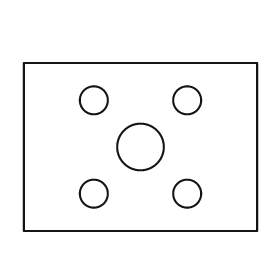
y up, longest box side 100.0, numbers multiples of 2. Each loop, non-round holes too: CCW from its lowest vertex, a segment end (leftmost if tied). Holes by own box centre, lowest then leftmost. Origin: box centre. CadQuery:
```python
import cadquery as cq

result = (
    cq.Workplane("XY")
    .moveTo(-50.0, -36.0)
    .lineTo(50.0, -36.0)
    .lineTo(50.0, 36.0)
    .lineTo(-50.0, 36.0)
    .close()
    .moveTo(-20.0, -20.0)
    .circle(6.0)
    .moveTo(20.0, -20.0)
    .circle(6.0)
    .moveTo(0.0, 0.0)
    .circle(10.0)
    .moveTo(-20.0, 20.0)
    .circle(6.0)
    .moveTo(20.0, 20.0)
    .circle(6.0)
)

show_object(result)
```